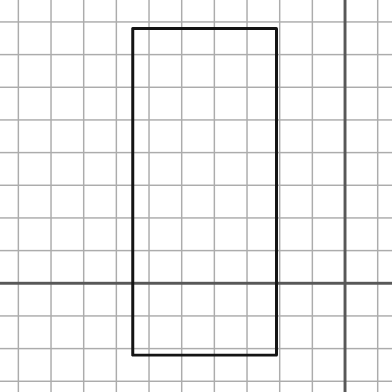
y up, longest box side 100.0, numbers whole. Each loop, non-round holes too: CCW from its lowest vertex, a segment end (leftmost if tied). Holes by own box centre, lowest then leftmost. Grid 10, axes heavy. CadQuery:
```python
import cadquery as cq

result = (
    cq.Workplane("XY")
    .moveTo(-65.0, -22.0)
    .lineTo(-21.0, -22.0)
    .lineTo(-21.0, 78.0)
    .lineTo(-65.0, 78.0)
    .close()
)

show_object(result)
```